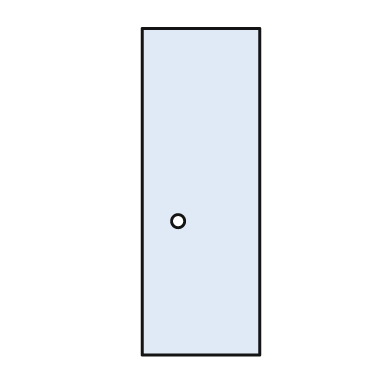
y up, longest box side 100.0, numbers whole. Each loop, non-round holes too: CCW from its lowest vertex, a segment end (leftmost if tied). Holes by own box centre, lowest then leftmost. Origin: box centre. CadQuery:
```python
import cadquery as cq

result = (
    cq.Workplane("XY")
    .moveTo(-18.0, -50.0)
    .lineTo(18.0, -50.0)
    .lineTo(18.0, 50.0)
    .lineTo(-18.0, 50.0)
    .close()
    .moveTo(-7.0, -9.0)
    .circle(2.0)
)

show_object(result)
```